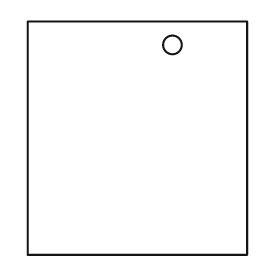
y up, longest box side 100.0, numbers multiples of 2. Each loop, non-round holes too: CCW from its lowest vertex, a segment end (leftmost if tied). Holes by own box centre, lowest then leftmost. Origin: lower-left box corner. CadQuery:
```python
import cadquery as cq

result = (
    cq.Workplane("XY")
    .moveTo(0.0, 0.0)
    .lineTo(94.0, 0.0)
    .lineTo(94.0, 100.0)
    .lineTo(0.0, 100.0)
    .close()
    .moveTo(62.0, 90.0)
    .circle(4.0)
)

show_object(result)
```